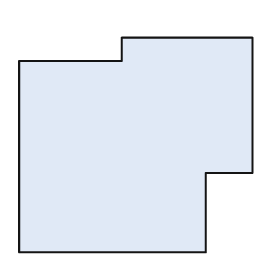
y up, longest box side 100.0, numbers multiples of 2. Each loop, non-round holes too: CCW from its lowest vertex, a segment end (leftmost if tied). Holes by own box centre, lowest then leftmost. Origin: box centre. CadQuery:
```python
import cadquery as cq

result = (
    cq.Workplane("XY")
    .moveTo(-50.0, -46.0)
    .lineTo(30.0, -46.0)
    .lineTo(30.0, -12.0)
    .lineTo(50.0, -12.0)
    .lineTo(50.0, 46.0)
    .lineTo(-6.0, 46.0)
    .lineTo(-6.0, 36.0)
    .lineTo(-50.0, 36.0)
    .close()
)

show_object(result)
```